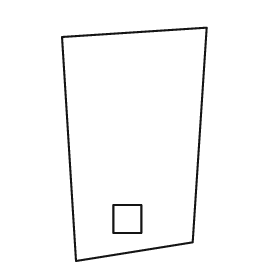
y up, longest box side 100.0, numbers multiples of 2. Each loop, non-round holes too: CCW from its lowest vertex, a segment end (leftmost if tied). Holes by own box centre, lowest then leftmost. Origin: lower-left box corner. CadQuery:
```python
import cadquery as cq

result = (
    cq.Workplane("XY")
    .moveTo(6.0, 0.0)
    .lineTo(56.0, 8.0)
    .lineTo(62.0, 100.0)
    .lineTo(0.0, 96.0)
    .close()
    .moveTo(22.0, 12.0)
    .lineTo(34.0, 12.0)
    .lineTo(34.0, 24.0)
    .lineTo(22.0, 24.0)
    .close()
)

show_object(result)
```